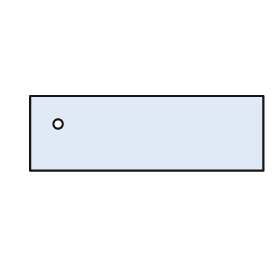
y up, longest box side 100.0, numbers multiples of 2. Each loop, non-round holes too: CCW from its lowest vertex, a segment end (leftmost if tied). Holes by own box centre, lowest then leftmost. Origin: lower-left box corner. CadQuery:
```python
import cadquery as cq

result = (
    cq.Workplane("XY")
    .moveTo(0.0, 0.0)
    .lineTo(100.0, 0.0)
    .lineTo(100.0, 32.0)
    .lineTo(0.0, 32.0)
    .close()
    .moveTo(12.0, 20.0)
    .circle(2.0)
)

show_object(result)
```